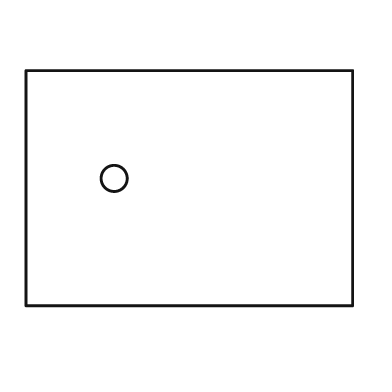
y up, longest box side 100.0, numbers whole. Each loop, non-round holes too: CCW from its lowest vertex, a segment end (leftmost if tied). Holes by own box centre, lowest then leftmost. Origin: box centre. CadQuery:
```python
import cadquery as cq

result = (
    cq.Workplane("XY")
    .moveTo(-50.0, -36.0)
    .lineTo(50.0, -36.0)
    .lineTo(50.0, 36.0)
    .lineTo(-50.0, 36.0)
    .close()
    .moveTo(-23.0, 3.0)
    .circle(4.0)
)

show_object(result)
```